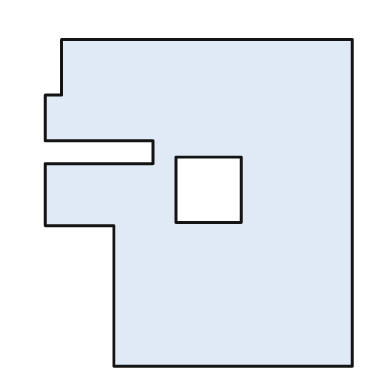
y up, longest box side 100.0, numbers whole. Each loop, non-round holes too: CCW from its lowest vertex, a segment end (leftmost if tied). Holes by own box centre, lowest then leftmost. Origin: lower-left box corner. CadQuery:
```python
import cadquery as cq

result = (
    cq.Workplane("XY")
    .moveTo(21.0, 0.0)
    .lineTo(94.0, 0.0)
    .lineTo(94.0, 100.0)
    .lineTo(5.0, 100.0)
    .lineTo(5.0, 83.0)
    .lineTo(0.0, 83.0)
    .lineTo(0.0, 69.0)
    .lineTo(33.0, 69.0)
    .lineTo(33.0, 62.0)
    .lineTo(0.0, 62.0)
    .lineTo(0.0, 43.0)
    .lineTo(21.0, 43.0)
    .close()
    .moveTo(40.0, 44.0)
    .lineTo(60.0, 44.0)
    .lineTo(60.0, 64.0)
    .lineTo(40.0, 64.0)
    .close()
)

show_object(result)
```